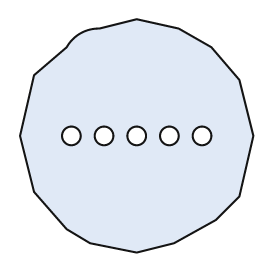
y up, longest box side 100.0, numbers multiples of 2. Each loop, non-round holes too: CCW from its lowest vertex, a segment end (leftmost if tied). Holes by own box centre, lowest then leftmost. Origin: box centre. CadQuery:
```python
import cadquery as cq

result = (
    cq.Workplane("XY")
    .moveTo(0.0, -50.0)
    .lineTo(16.0, -46.0)
    .lineTo(34.0, -36.0)
    .lineTo(44.0, -26.0)
    .lineTo(50.0, 0.0)
    .lineTo(44.0, 24.0)
    .lineTo(32.0, 38.0)
    .lineTo(18.0, 46.0)
    .lineTo(0.0, 50.0)
    .lineTo(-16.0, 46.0)
    .threePointArc((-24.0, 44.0), (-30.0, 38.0))
    .lineTo(-44.0, 26.0)
    .lineTo(-50.0, 0.0)
    .lineTo(-44.0, -24.0)
    .lineTo(-30.0, -40.0)
    .lineTo(-20.0, -46.0)
    .close()
    .moveTo(-28.0, 0.0)
    .circle(4.0)
    .moveTo(-14.0, 0.0)
    .circle(4.0)
    .moveTo(0.0, 0.0)
    .circle(4.0)
    .moveTo(14.0, 0.0)
    .circle(4.0)
    .moveTo(28.0, 0.0)
    .circle(4.0)
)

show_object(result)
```